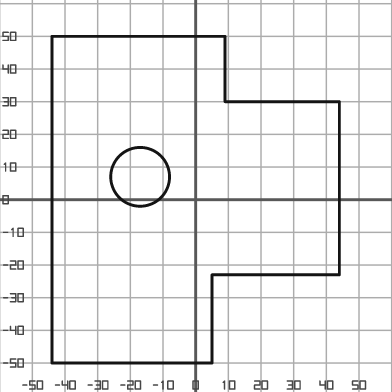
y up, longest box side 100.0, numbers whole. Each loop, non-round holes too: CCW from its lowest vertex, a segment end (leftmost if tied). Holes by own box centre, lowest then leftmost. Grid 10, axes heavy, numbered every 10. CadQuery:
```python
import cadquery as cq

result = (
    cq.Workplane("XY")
    .moveTo(-44.0, -50.0)
    .lineTo(5.0, -50.0)
    .lineTo(5.0, -23.0)
    .lineTo(44.0, -23.0)
    .lineTo(44.0, 30.0)
    .lineTo(9.0, 30.0)
    .lineTo(9.0, 50.0)
    .lineTo(-44.0, 50.0)
    .close()
    .moveTo(-17.0, 7.0)
    .circle(9.0)
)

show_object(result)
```